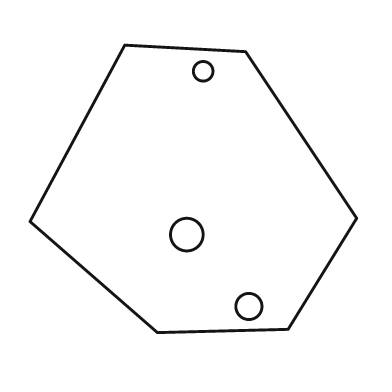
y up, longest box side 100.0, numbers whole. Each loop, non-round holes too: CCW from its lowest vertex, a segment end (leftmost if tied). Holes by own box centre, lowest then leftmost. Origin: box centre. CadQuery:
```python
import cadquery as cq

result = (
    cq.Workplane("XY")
    .moveTo(-11.0, -44.0)
    .lineTo(29.0, -43.0)
    .lineTo(50.0, -9.0)
    .lineTo(16.0, 42.0)
    .lineTo(-21.0, 44.0)
    .lineTo(-50.0, -10.0)
    .close()
    .moveTo(17.0, -36.0)
    .circle(4.0)
    .moveTo(-2.0, -14.0)
    .circle(5.0)
    .moveTo(3.0, 36.0)
    .circle(3.0)
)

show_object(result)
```